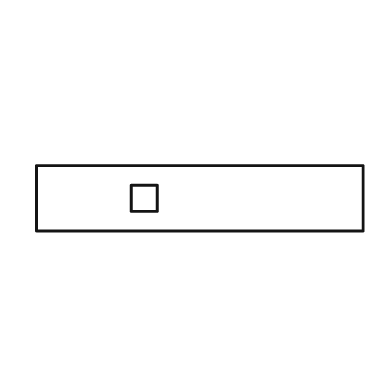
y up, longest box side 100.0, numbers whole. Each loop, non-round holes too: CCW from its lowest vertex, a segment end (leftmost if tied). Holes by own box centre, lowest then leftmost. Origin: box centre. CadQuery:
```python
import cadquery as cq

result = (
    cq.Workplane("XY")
    .moveTo(-50.0, -10.0)
    .lineTo(50.0, -10.0)
    .lineTo(50.0, 10.0)
    .lineTo(-50.0, 10.0)
    .close()
    .moveTo(-21.0, -4.0)
    .lineTo(-13.0, -4.0)
    .lineTo(-13.0, 4.0)
    .lineTo(-21.0, 4.0)
    .close()
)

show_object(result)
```